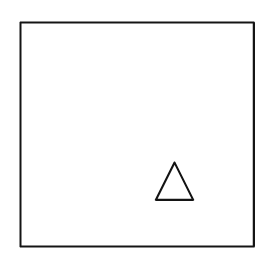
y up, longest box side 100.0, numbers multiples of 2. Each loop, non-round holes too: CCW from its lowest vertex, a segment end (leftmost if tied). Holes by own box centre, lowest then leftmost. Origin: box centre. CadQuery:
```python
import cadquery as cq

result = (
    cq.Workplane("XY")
    .moveTo(-50.0, -48.0)
    .lineTo(50.0, -48.0)
    .lineTo(50.0, 48.0)
    .lineTo(-50.0, 48.0)
    .close()
    .moveTo(8.0, -28.0)
    .lineTo(24.0, -28.0)
    .lineTo(16.0, -12.0)
    .close()
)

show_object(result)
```